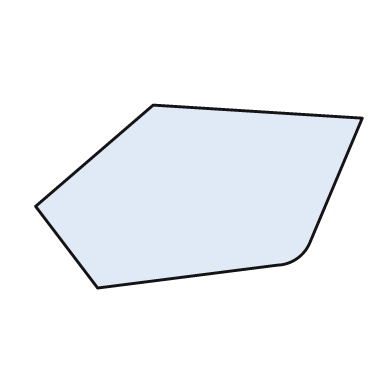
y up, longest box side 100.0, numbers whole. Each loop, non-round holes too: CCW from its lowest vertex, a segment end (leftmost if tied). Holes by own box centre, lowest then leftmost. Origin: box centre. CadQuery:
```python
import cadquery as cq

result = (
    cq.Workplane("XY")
    .moveTo(-31.0, -28.0)
    .lineTo(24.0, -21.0)
    .threePointArc((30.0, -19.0), (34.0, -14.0))
    .lineTo(50.0, 24.0)
    .lineTo(-14.0, 28.0)
    .lineTo(-50.0, -3.0)
    .close()
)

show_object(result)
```